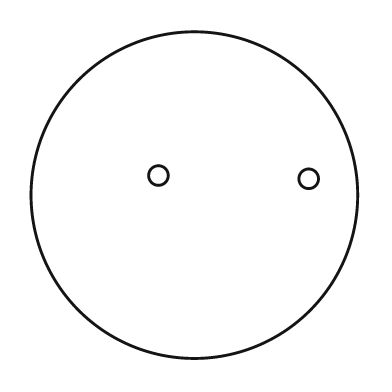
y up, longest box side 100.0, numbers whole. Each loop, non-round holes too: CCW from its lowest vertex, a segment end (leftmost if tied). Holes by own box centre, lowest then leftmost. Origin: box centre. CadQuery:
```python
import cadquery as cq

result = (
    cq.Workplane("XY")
    .moveTo(0.0, 0.0)
    .circle(50.0)
    .moveTo(35.0, 5.0)
    .circle(3.0)
    .moveTo(-11.0, 6.0)
    .circle(3.0)
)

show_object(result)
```